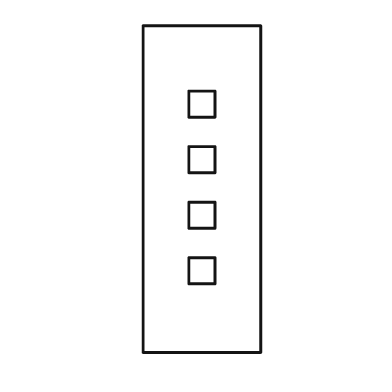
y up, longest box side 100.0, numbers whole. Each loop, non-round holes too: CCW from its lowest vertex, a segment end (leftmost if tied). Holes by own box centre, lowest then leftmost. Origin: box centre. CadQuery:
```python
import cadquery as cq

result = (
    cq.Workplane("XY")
    .moveTo(-18.0, -50.0)
    .lineTo(18.0, -50.0)
    .lineTo(18.0, 50.0)
    .lineTo(-18.0, 50.0)
    .close()
    .moveTo(-4.0, -29.0)
    .lineTo(4.0, -29.0)
    .lineTo(4.0, -21.0)
    .lineTo(-4.0, -21.0)
    .close()
    .moveTo(-4.0, -12.0)
    .lineTo(4.0, -12.0)
    .lineTo(4.0, -4.0)
    .lineTo(-4.0, -4.0)
    .close()
    .moveTo(-4.0, 5.0)
    .lineTo(4.0, 5.0)
    .lineTo(4.0, 13.0)
    .lineTo(-4.0, 13.0)
    .close()
    .moveTo(-4.0, 22.0)
    .lineTo(4.0, 22.0)
    .lineTo(4.0, 30.0)
    .lineTo(-4.0, 30.0)
    .close()
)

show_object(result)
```